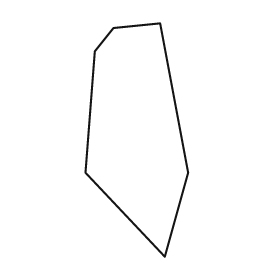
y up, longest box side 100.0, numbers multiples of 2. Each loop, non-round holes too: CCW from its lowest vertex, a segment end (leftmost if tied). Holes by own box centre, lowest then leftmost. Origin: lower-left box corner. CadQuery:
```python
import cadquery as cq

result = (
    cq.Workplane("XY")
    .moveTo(34.0, 0.0)
    .lineTo(44.0, 36.0)
    .lineTo(32.0, 100.0)
    .lineTo(12.0, 98.0)
    .lineTo(4.0, 88.0)
    .lineTo(0.0, 36.0)
    .close()
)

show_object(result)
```